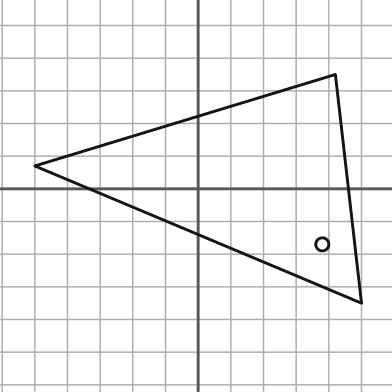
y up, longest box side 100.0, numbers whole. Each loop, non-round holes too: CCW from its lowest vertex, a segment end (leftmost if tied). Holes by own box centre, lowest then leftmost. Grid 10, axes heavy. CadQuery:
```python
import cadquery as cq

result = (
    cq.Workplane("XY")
    .moveTo(50.0, -35.0)
    .lineTo(42.0, 35.0)
    .lineTo(-50.0, 7.0)
    .close()
    .moveTo(38.0, -17.0)
    .circle(2.0)
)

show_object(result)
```